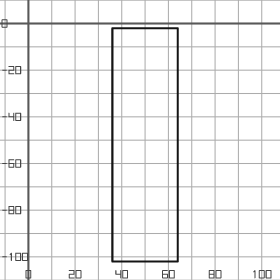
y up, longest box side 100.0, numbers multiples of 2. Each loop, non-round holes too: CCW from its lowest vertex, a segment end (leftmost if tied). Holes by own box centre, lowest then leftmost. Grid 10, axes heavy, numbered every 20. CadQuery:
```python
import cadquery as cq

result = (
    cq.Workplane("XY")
    .moveTo(36.0, -102.0)
    .lineTo(64.0, -102.0)
    .lineTo(64.0, -2.0)
    .lineTo(36.0, -2.0)
    .close()
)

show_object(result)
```